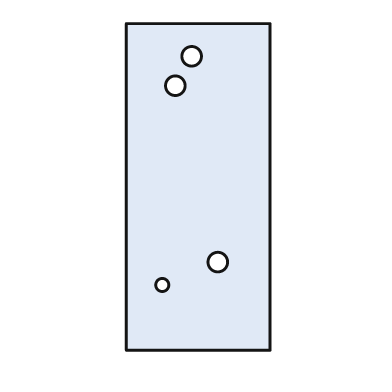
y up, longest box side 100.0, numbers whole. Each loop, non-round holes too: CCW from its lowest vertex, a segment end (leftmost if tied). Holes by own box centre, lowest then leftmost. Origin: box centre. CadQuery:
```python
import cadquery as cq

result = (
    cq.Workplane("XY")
    .moveTo(-22.0, -50.0)
    .lineTo(22.0, -50.0)
    .lineTo(22.0, 50.0)
    .lineTo(-22.0, 50.0)
    .close()
    .moveTo(-11.0, -30.0)
    .circle(2.0)
    .moveTo(6.0, -23.0)
    .circle(3.0)
    .moveTo(-7.0, 31.0)
    .circle(3.0)
    .moveTo(-2.0, 40.0)
    .circle(3.0)
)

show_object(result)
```